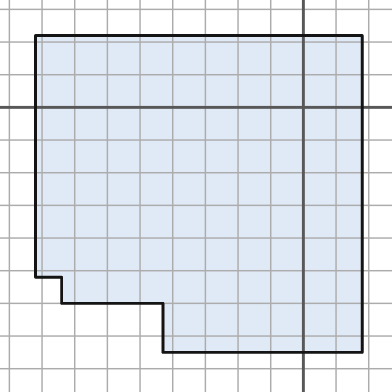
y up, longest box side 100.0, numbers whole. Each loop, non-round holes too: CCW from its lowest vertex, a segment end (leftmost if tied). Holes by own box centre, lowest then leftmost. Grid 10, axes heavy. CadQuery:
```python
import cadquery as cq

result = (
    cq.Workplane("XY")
    .moveTo(-43.0, -75.0)
    .lineTo(18.0, -75.0)
    .lineTo(18.0, 22.0)
    .lineTo(-82.0, 22.0)
    .lineTo(-82.0, -52.0)
    .lineTo(-74.0, -52.0)
    .lineTo(-74.0, -60.0)
    .lineTo(-43.0, -60.0)
    .close()
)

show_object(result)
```